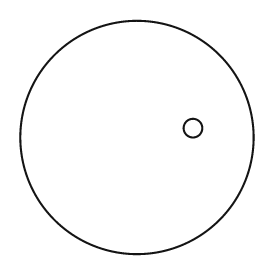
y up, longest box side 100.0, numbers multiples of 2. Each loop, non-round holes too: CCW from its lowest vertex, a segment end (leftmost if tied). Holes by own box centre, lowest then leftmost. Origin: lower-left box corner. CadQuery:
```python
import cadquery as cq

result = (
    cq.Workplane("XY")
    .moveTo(50.0, 50.0)
    .circle(50.0)
    .moveTo(74.0, 54.0)
    .circle(4.0)
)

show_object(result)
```